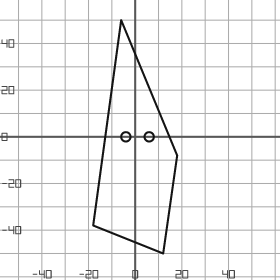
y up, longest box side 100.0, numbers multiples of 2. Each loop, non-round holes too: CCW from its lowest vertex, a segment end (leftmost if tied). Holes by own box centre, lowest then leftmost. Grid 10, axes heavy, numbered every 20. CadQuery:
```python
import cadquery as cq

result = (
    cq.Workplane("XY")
    .moveTo(12.0, -50.0)
    .lineTo(18.0, -8.0)
    .lineTo(-6.0, 50.0)
    .lineTo(-18.0, -38.0)
    .close()
    .moveTo(-4.0, 0.0)
    .circle(2.0)
    .moveTo(6.0, 0.0)
    .circle(2.0)
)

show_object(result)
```